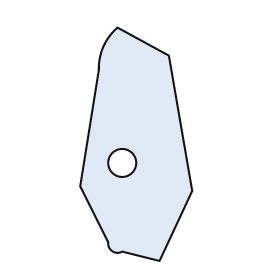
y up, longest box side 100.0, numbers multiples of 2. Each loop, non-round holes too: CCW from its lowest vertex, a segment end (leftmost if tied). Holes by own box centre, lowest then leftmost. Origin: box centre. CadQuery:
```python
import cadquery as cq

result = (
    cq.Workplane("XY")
    .moveTo(10.0, -50.0)
    .lineTo(24.0, -20.0)
    .lineTo(14.0, 38.0)
    .lineTo(-8.0, 50.0)
    .threePointArc((-14.0, 42.0), (-16.0, 32.0))
    .lineTo(-24.0, -18.0)
    .lineTo(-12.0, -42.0)
    .threePointArc((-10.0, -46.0), (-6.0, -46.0))
    .close()
    .moveTo(-6.0, -8.0)
    .circle(6.0)
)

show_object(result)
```